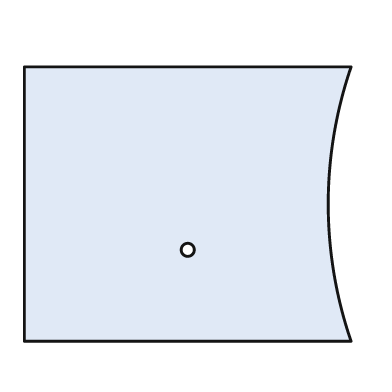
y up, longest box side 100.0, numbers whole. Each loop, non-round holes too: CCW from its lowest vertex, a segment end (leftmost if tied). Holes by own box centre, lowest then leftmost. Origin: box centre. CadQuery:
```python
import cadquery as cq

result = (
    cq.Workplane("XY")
    .moveTo(-50.0, -42.0)
    .lineTo(50.0, -42.0)
    .threePointArc((43.0, 0.0), (50.0, 42.0))
    .lineTo(-50.0, 42.0)
    .close()
    .moveTo(0.0, -14.0)
    .circle(2.0)
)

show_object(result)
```